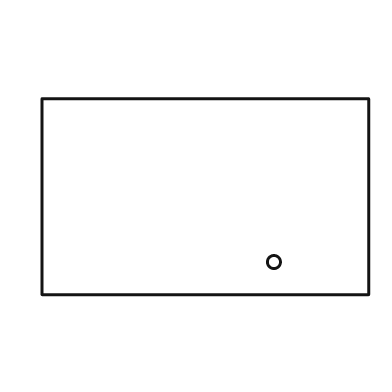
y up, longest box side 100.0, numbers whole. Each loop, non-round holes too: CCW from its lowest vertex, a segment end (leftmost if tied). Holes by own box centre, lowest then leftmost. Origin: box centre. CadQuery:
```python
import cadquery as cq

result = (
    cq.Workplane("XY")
    .moveTo(-50.0, -30.0)
    .lineTo(50.0, -30.0)
    .lineTo(50.0, 30.0)
    .lineTo(-50.0, 30.0)
    .close()
    .moveTo(21.0, -20.0)
    .circle(2.0)
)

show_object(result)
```